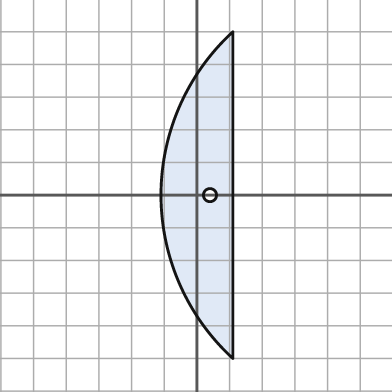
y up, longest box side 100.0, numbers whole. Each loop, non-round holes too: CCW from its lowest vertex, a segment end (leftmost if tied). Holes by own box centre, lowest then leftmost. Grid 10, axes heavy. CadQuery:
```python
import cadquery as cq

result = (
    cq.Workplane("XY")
    .moveTo(11.0, -50.0)
    .lineTo(11.0, 50.0)
    .threePointArc((-11.0, 0.0), (11.0, -50.0))
    .close()
    .moveTo(4.0, 0.0)
    .circle(2.0)
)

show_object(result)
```